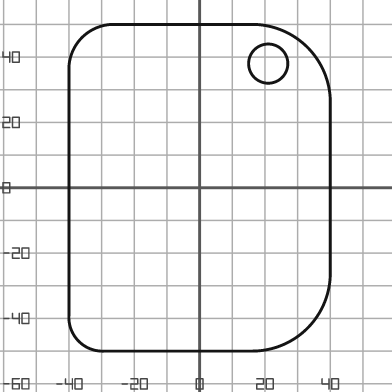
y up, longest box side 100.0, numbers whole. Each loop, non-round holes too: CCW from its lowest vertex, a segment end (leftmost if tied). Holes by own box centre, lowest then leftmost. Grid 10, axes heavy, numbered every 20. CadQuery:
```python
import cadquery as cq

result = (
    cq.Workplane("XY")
    .moveTo(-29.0, -50.0)
    .lineTo(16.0, -50.0)
    .threePointArc((33.0, -43.0), (40.0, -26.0))
    .lineTo(40.0, 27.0)
    .threePointArc((33.0, 43.0), (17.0, 50.0))
    .lineTo(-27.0, 50.0)
    .threePointArc((-36.0, 46.0), (-40.0, 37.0))
    .lineTo(-40.0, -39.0)
    .threePointArc((-37.0, -47.0), (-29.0, -50.0))
    .close()
    .moveTo(21.0, 38.0)
    .circle(6.0)
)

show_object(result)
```